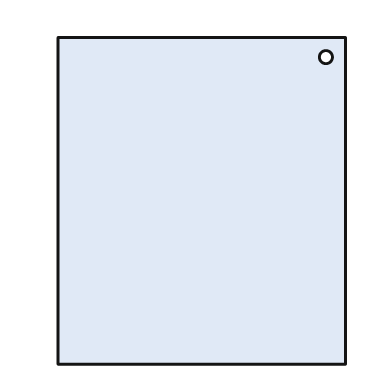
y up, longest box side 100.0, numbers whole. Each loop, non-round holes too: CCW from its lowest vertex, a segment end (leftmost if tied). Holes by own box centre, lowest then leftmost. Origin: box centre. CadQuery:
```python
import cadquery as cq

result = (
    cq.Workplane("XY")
    .moveTo(-44.0, -50.0)
    .lineTo(44.0, -50.0)
    .lineTo(44.0, 50.0)
    .lineTo(-44.0, 50.0)
    .close()
    .moveTo(38.0, 44.0)
    .circle(2.0)
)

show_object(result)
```